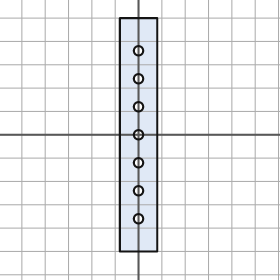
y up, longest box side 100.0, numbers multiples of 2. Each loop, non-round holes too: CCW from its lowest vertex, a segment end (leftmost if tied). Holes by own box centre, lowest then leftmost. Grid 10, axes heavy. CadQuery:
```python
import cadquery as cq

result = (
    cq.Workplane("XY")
    .moveTo(-8.0, -50.0)
    .lineTo(8.0, -50.0)
    .lineTo(8.0, 50.0)
    .lineTo(-8.0, 50.0)
    .close()
    .moveTo(0.0, -36.0)
    .circle(2.0)
    .moveTo(0.0, -24.0)
    .circle(2.0)
    .moveTo(0.0, -12.0)
    .circle(2.0)
    .moveTo(0.0, 0.0)
    .circle(2.0)
    .moveTo(0.0, 12.0)
    .circle(2.0)
    .moveTo(0.0, 24.0)
    .circle(2.0)
    .moveTo(0.0, 36.0)
    .circle(2.0)
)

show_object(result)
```